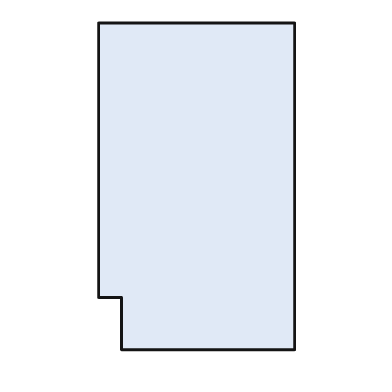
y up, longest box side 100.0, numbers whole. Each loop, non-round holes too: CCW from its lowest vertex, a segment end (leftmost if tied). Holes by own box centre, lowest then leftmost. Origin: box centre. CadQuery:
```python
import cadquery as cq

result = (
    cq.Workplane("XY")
    .moveTo(-23.0, -50.0)
    .lineTo(30.0, -50.0)
    .lineTo(30.0, 50.0)
    .lineTo(-30.0, 50.0)
    .lineTo(-30.0, -34.0)
    .lineTo(-23.0, -34.0)
    .close()
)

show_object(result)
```